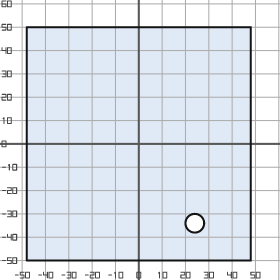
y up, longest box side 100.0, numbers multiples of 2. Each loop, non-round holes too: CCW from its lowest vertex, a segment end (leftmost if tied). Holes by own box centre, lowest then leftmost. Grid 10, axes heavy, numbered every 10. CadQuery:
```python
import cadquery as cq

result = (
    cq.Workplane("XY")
    .moveTo(-48.0, -50.0)
    .lineTo(48.0, -50.0)
    .lineTo(48.0, 50.0)
    .lineTo(-48.0, 50.0)
    .close()
    .moveTo(24.0, -34.0)
    .circle(4.0)
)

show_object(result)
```